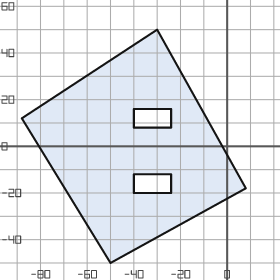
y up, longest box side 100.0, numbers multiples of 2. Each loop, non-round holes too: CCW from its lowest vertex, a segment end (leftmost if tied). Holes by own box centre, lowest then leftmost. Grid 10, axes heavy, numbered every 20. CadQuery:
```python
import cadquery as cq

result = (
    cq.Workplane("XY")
    .moveTo(-50.0, -50.0)
    .lineTo(8.0, -18.0)
    .lineTo(-30.0, 50.0)
    .lineTo(-88.0, 12.0)
    .close()
    .moveTo(-40.0, -20.0)
    .lineTo(-24.0, -20.0)
    .lineTo(-24.0, -12.0)
    .lineTo(-40.0, -12.0)
    .close()
    .moveTo(-40.0, 8.0)
    .lineTo(-24.0, 8.0)
    .lineTo(-24.0, 16.0)
    .lineTo(-40.0, 16.0)
    .close()
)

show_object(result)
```